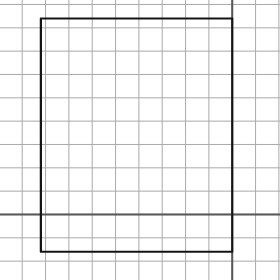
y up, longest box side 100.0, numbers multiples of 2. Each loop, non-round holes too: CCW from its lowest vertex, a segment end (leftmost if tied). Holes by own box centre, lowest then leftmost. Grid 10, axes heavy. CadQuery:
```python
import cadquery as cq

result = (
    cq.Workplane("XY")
    .moveTo(-82.0, -16.0)
    .lineTo(0.0, -16.0)
    .lineTo(0.0, 84.0)
    .lineTo(-82.0, 84.0)
    .close()
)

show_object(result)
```